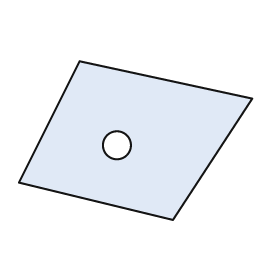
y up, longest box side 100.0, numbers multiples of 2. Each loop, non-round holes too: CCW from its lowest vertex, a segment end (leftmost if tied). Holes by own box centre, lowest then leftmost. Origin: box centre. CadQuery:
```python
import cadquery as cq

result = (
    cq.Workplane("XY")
    .moveTo(16.0, -34.0)
    .lineTo(50.0, 18.0)
    .lineTo(-24.0, 34.0)
    .lineTo(-50.0, -18.0)
    .close()
    .moveTo(-8.0, -2.0)
    .circle(6.0)
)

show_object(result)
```